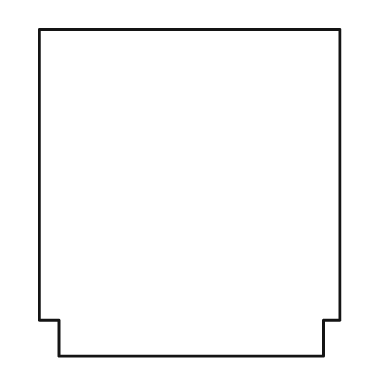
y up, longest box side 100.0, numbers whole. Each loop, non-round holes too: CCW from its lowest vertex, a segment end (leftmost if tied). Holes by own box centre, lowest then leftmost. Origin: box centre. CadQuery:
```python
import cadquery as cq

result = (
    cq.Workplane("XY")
    .moveTo(-40.0, -50.0)
    .lineTo(41.0, -50.0)
    .lineTo(41.0, -39.0)
    .lineTo(46.0, -39.0)
    .lineTo(46.0, 50.0)
    .lineTo(-46.0, 50.0)
    .lineTo(-46.0, -39.0)
    .lineTo(-40.0, -39.0)
    .close()
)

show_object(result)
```